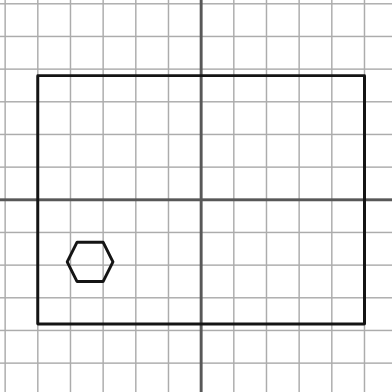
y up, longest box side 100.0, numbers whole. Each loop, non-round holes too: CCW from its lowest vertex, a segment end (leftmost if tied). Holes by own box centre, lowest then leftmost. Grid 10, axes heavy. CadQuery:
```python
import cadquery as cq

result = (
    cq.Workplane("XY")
    .moveTo(-50.0, -38.0)
    .lineTo(50.0, -38.0)
    .lineTo(50.0, 38.0)
    .lineTo(-50.0, 38.0)
    .close()
    .moveTo(-38.0, -25.0)
    .lineTo(-30.0, -25.0)
    .lineTo(-27.0, -19.0)
    .lineTo(-30.0, -13.0)
    .lineTo(-38.0, -13.0)
    .lineTo(-41.0, -19.0)
    .close()
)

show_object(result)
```